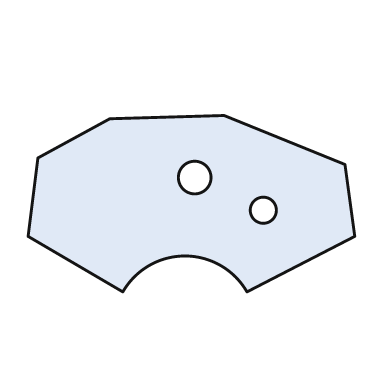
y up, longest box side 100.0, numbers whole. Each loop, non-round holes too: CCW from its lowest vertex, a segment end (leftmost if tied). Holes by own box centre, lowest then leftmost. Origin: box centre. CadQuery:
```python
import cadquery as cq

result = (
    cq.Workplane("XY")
    .moveTo(-21.0, -27.0)
    .threePointArc((-2.0, -16.0), (17.0, -27.0))
    .lineTo(50.0, -10.0)
    .lineTo(47.0, 12.0)
    .lineTo(10.0, 27.0)
    .lineTo(-25.0, 26.0)
    .lineTo(-47.0, 14.0)
    .lineTo(-50.0, -10.0)
    .close()
    .moveTo(22.0, -2.0)
    .circle(4.0)
    .moveTo(1.0, 8.0)
    .circle(5.0)
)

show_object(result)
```